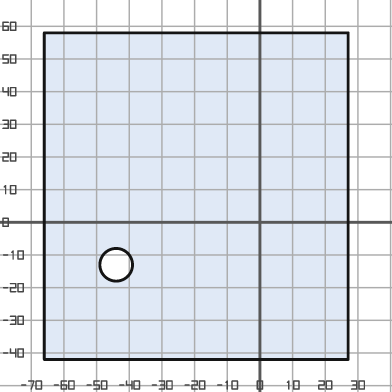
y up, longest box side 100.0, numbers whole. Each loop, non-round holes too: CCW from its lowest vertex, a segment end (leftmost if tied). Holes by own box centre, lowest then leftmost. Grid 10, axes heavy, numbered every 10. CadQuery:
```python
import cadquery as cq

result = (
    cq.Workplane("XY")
    .moveTo(-66.0, -42.0)
    .lineTo(27.0, -42.0)
    .lineTo(27.0, 58.0)
    .lineTo(-66.0, 58.0)
    .close()
    .moveTo(-44.0, -13.0)
    .circle(5.0)
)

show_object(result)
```